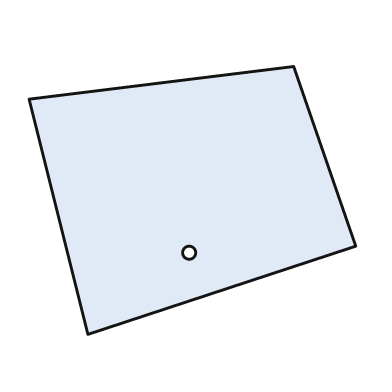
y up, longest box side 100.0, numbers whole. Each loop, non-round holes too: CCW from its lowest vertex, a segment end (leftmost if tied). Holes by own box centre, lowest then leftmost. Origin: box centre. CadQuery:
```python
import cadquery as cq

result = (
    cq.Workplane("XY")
    .moveTo(-32.0, -41.0)
    .lineTo(50.0, -14.0)
    .lineTo(31.0, 41.0)
    .lineTo(-50.0, 31.0)
    .close()
    .moveTo(-1.0, -16.0)
    .circle(2.0)
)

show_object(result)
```